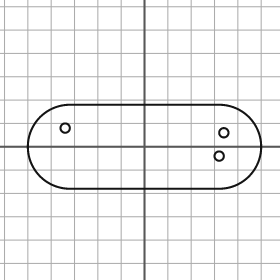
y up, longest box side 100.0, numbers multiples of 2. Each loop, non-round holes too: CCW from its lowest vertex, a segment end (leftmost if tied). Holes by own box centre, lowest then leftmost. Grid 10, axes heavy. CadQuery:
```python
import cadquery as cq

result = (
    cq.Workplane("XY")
    .moveTo(-32.0, -18.0)
    .lineTo(32.0, -18.0)
    .threePointArc((50.0, 0.0), (32.0, 18.0))
    .lineTo(-32.0, 18.0)
    .threePointArc((-50.0, 0.0), (-32.0, -18.0))
    .close()
    .moveTo(32.0, -4.0)
    .circle(2.0)
    .moveTo(34.0, 6.0)
    .circle(2.0)
    .moveTo(-34.0, 8.0)
    .circle(2.0)
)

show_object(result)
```